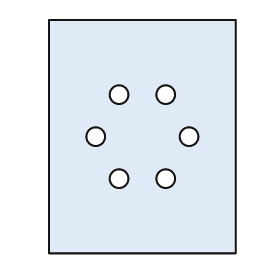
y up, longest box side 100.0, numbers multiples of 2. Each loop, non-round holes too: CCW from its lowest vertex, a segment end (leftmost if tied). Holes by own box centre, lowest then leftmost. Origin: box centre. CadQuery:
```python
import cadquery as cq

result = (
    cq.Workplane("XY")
    .moveTo(-40.0, -50.0)
    .lineTo(40.0, -50.0)
    .lineTo(40.0, 50.0)
    .lineTo(-40.0, 50.0)
    .close()
    .moveTo(-10.0, -18.0)
    .circle(4.0)
    .moveTo(10.0, -18.0)
    .circle(4.0)
    .moveTo(-20.0, 0.0)
    .circle(4.0)
    .moveTo(20.0, 0.0)
    .circle(4.0)
    .moveTo(-10.0, 18.0)
    .circle(4.0)
    .moveTo(10.0, 18.0)
    .circle(4.0)
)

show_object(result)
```